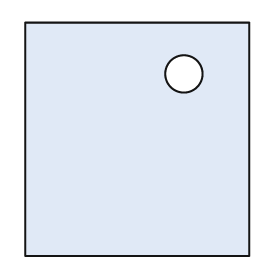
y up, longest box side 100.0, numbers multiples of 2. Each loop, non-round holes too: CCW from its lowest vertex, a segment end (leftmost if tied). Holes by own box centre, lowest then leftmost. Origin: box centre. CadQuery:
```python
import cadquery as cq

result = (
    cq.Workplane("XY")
    .moveTo(-48.0, -50.0)
    .lineTo(48.0, -50.0)
    .lineTo(48.0, 50.0)
    .lineTo(-48.0, 50.0)
    .close()
    .moveTo(20.0, 28.0)
    .circle(8.0)
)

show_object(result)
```